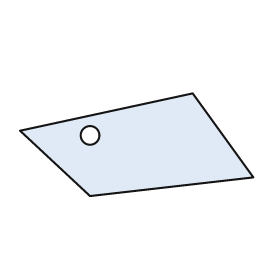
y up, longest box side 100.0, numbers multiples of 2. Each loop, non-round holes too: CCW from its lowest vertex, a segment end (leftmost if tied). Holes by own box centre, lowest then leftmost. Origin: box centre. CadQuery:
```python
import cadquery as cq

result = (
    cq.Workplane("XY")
    .moveTo(-20.0, -22.0)
    .lineTo(50.0, -14.0)
    .lineTo(24.0, 22.0)
    .lineTo(-50.0, 6.0)
    .close()
    .moveTo(-20.0, 4.0)
    .circle(4.0)
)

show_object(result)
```